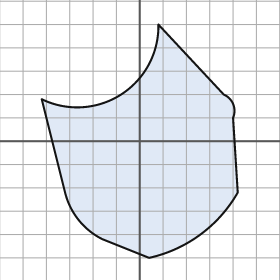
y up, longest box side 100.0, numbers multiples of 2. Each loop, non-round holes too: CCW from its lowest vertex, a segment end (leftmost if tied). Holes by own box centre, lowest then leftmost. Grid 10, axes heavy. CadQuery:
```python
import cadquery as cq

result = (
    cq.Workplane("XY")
    .moveTo(4.0, -50.0)
    .threePointArc((26.0, -40.0), (42.0, -22.0))
    .lineTo(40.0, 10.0)
    .threePointArc((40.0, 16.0), (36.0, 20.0))
    .lineTo(8.0, 50.0)
    .threePointArc((-8.0, 20.0), (-42.0, 18.0))
    .lineTo(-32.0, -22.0)
    .threePointArc((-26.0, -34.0), (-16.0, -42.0))
    .close()
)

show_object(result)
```